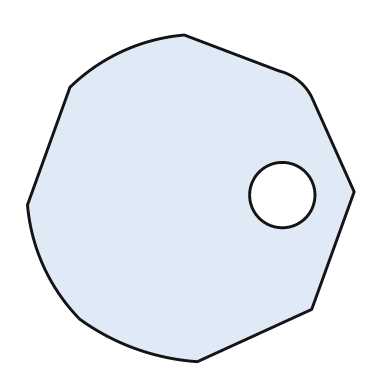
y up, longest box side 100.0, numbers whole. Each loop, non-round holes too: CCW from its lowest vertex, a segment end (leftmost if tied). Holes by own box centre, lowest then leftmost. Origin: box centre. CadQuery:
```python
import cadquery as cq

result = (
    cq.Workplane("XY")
    .moveTo(2.0, -50.0)
    .lineTo(37.0, -34.0)
    .lineTo(50.0, 2.0)
    .lineTo(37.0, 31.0)
    .threePointArc((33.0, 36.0), (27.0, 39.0))
    .lineTo(-2.0, 50.0)
    .threePointArc((-21.0, 45.0), (-37.0, 34.0))
    .lineTo(-50.0, -2.0)
    .threePointArc((-45.0, -21.0), (-34.0, -37.0))
    .threePointArc((-17.0, -46.0), (2.0, -50.0))
    .close()
    .moveTo(28.0, 1.0)
    .circle(10.0)
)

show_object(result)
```